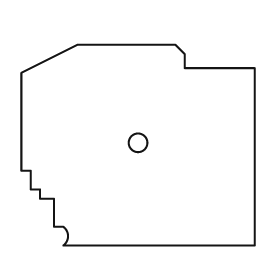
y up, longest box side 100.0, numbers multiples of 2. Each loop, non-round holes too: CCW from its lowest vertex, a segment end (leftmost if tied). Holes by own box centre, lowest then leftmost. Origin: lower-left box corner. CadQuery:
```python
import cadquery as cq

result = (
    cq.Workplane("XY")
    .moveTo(18.0, 0.0)
    .lineTo(100.0, 0.0)
    .lineTo(100.0, 76.0)
    .lineTo(70.0, 76.0)
    .lineTo(70.0, 82.0)
    .lineTo(66.0, 86.0)
    .lineTo(24.0, 86.0)
    .lineTo(0.0, 74.0)
    .lineTo(0.0, 32.0)
    .lineTo(4.0, 32.0)
    .lineTo(4.0, 24.0)
    .lineTo(8.0, 24.0)
    .lineTo(8.0, 20.0)
    .lineTo(14.0, 20.0)
    .lineTo(14.0, 8.0)
    .lineTo(18.0, 8.0)
    .threePointArc((20.0, 4.0), (18.0, 0.0))
    .close()
    .moveTo(50.0, 44.0)
    .circle(4.0)
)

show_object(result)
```